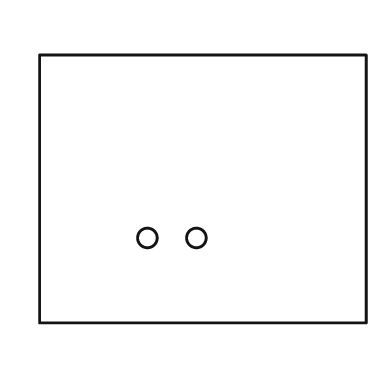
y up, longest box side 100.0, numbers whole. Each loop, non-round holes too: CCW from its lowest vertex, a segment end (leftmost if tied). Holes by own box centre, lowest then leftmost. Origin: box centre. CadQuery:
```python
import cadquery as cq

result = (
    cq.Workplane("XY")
    .moveTo(-50.0, -41.0)
    .lineTo(50.0, -41.0)
    .lineTo(50.0, 41.0)
    .lineTo(-50.0, 41.0)
    .close()
    .moveTo(-17.0, -15.0)
    .circle(3.0)
    .moveTo(-2.0, -15.0)
    .circle(3.0)
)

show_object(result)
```